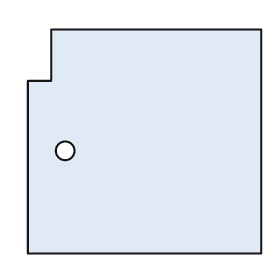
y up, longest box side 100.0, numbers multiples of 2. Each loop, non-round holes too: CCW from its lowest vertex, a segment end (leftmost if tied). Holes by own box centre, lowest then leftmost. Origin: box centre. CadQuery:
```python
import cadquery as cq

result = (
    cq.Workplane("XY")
    .moveTo(-50.0, -48.0)
    .lineTo(50.0, -48.0)
    .lineTo(50.0, 48.0)
    .lineTo(-40.0, 48.0)
    .lineTo(-40.0, 26.0)
    .lineTo(-50.0, 26.0)
    .close()
    .moveTo(-34.0, -4.0)
    .circle(4.0)
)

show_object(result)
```